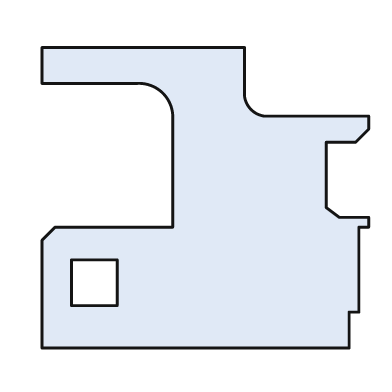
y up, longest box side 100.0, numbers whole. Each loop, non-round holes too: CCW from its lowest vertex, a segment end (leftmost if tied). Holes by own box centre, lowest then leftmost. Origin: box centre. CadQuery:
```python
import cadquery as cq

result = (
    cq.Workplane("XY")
    .moveTo(-50.0, -46.0)
    .lineTo(44.0, -46.0)
    .lineTo(44.0, -35.0)
    .lineTo(47.0, -35.0)
    .lineTo(47.0, -9.0)
    .lineTo(50.0, -9.0)
    .lineTo(50.0, -6.0)
    .lineTo(41.0, -6.0)
    .lineTo(37.0, -3.0)
    .lineTo(37.0, 17.0)
    .lineTo(46.0, 17.0)
    .lineTo(50.0, 21.0)
    .lineTo(50.0, 25.0)
    .lineTo(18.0, 25.0)
    .threePointArc((14.0, 27.0), (12.0, 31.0))
    .lineTo(12.0, 46.0)
    .lineTo(-50.0, 46.0)
    .lineTo(-50.0, 35.0)
    .lineTo(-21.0, 35.0)
    .threePointArc((-13.0, 32.0), (-10.0, 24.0))
    .lineTo(-10.0, -9.0)
    .lineTo(-46.0, -9.0)
    .lineTo(-50.0, -13.0)
    .close()
    .moveTo(-41.0, -33.0)
    .lineTo(-27.0, -33.0)
    .lineTo(-27.0, -19.0)
    .lineTo(-41.0, -19.0)
    .close()
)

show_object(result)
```